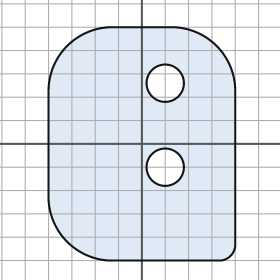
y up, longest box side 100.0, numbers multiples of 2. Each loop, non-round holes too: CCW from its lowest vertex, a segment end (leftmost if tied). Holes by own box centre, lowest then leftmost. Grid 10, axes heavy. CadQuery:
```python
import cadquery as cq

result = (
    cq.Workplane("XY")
    .moveTo(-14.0, -50.0)
    .lineTo(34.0, -50.0)
    .threePointArc((38.0, -48.0), (40.0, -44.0))
    .lineTo(40.0, 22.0)
    .threePointArc((32.0, 42.0), (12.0, 50.0))
    .lineTo(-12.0, 50.0)
    .threePointArc((-32.0, 42.0), (-40.0, 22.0))
    .lineTo(-40.0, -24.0)
    .threePointArc((-32.0, -42.0), (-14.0, -50.0))
    .close()
    .moveTo(10.0, -10.0)
    .circle(8.0)
    .moveTo(10.0, 26.0)
    .circle(8.0)
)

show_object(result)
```